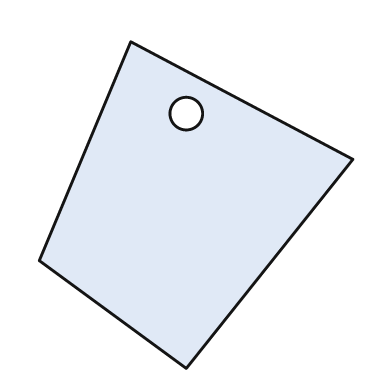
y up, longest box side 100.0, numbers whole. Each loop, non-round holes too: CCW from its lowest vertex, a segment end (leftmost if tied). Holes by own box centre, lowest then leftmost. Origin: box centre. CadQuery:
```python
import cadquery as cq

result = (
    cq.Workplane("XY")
    .moveTo(-3.0, -50.0)
    .lineTo(48.0, 14.0)
    .lineTo(-20.0, 50.0)
    .lineTo(-48.0, -17.0)
    .close()
    .moveTo(-3.0, 28.0)
    .circle(5.0)
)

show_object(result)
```